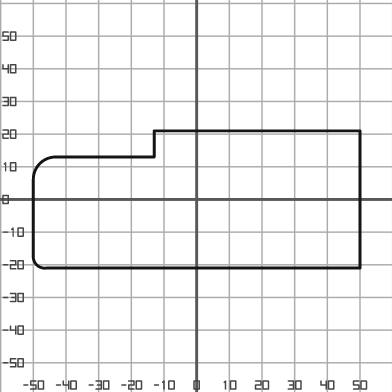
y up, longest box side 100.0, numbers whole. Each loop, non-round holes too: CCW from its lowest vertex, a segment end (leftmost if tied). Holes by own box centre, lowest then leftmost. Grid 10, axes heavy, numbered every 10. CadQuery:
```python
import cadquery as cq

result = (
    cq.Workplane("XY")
    .moveTo(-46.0, -21.0)
    .lineTo(50.0, -21.0)
    .lineTo(50.0, 21.0)
    .lineTo(-13.0, 21.0)
    .lineTo(-13.0, 13.0)
    .lineTo(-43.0, 13.0)
    .threePointArc((-48.0, 11.0), (-50.0, 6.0))
    .lineTo(-50.0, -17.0)
    .threePointArc((-49.0, -20.0), (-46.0, -21.0))
    .close()
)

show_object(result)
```